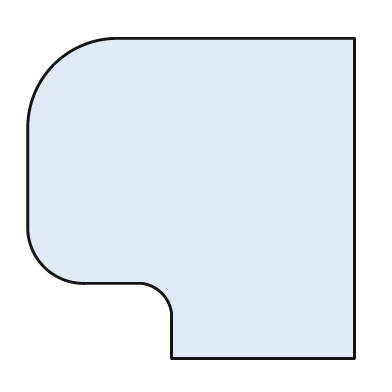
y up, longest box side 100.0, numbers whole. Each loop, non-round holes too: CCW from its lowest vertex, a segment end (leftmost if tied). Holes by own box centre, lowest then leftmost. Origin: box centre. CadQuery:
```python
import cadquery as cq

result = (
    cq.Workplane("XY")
    .moveTo(-6.0, -49.0)
    .lineTo(50.0, -49.0)
    .lineTo(50.0, 49.0)
    .lineTo(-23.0, 49.0)
    .threePointArc((-42.0, 41.0), (-50.0, 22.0))
    .lineTo(-50.0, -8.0)
    .threePointArc((-45.0, -21.0), (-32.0, -26.0))
    .lineTo(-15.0, -26.0)
    .threePointArc((-9.0, -29.0), (-6.0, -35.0))
    .close()
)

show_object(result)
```